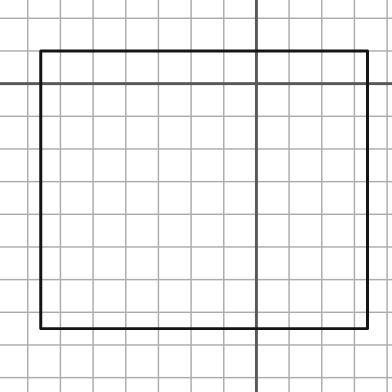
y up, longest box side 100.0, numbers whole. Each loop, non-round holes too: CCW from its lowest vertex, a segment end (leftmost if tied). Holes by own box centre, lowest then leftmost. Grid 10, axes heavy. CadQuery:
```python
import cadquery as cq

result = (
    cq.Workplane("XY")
    .moveTo(-66.0, -75.0)
    .lineTo(34.0, -75.0)
    .lineTo(34.0, 10.0)
    .lineTo(-66.0, 10.0)
    .close()
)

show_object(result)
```